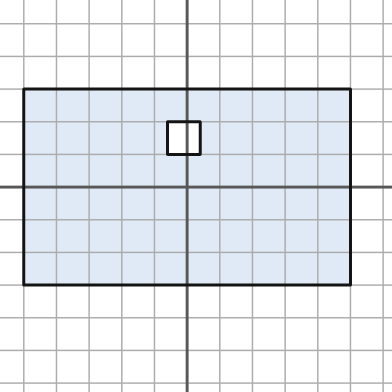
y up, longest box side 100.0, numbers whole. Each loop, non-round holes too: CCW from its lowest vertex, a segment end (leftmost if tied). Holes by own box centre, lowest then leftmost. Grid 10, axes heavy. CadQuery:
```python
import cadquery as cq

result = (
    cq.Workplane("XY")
    .moveTo(-50.0, -30.0)
    .lineTo(50.0, -30.0)
    .lineTo(50.0, 30.0)
    .lineTo(-50.0, 30.0)
    .close()
    .moveTo(-6.0, 10.0)
    .lineTo(4.0, 10.0)
    .lineTo(4.0, 20.0)
    .lineTo(-6.0, 20.0)
    .close()
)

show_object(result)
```